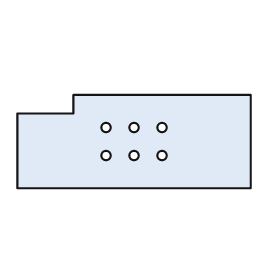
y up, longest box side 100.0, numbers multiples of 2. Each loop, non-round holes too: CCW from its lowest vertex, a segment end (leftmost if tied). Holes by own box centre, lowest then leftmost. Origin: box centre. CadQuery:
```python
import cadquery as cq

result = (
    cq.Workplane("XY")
    .moveTo(-50.0, -20.0)
    .lineTo(50.0, -20.0)
    .lineTo(50.0, 20.0)
    .lineTo(-26.0, 20.0)
    .lineTo(-26.0, 12.0)
    .lineTo(-50.0, 12.0)
    .close()
    .moveTo(-12.0, -6.0)
    .circle(2.0)
    .moveTo(0.0, -6.0)
    .circle(2.0)
    .moveTo(12.0, -6.0)
    .circle(2.0)
    .moveTo(-12.0, 6.0)
    .circle(2.0)
    .moveTo(0.0, 6.0)
    .circle(2.0)
    .moveTo(12.0, 6.0)
    .circle(2.0)
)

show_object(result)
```